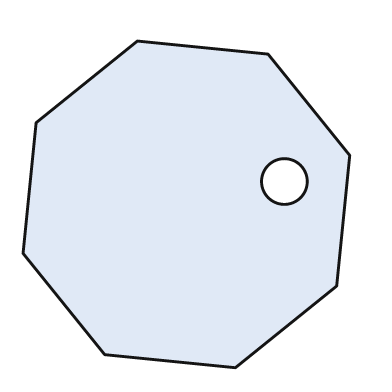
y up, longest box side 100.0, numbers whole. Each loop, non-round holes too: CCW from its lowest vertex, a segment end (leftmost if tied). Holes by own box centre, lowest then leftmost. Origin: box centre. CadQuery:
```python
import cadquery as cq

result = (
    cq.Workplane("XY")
    .moveTo(15.0, -50.0)
    .lineTo(46.0, -25.0)
    .lineTo(50.0, 15.0)
    .lineTo(25.0, 46.0)
    .lineTo(-15.0, 50.0)
    .lineTo(-46.0, 25.0)
    .lineTo(-50.0, -15.0)
    .lineTo(-25.0, -46.0)
    .close()
    .moveTo(30.0, 7.0)
    .circle(7.0)
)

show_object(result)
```